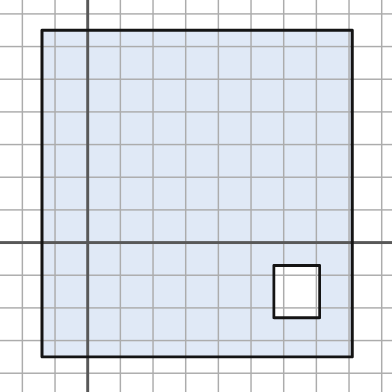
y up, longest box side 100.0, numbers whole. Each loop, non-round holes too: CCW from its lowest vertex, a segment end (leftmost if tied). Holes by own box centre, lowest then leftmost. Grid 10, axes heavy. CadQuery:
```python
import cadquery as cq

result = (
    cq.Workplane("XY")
    .moveTo(-14.0, -35.0)
    .lineTo(81.0, -35.0)
    .lineTo(81.0, 65.0)
    .lineTo(-14.0, 65.0)
    .close()
    .moveTo(57.0, -23.0)
    .lineTo(71.0, -23.0)
    .lineTo(71.0, -7.0)
    .lineTo(57.0, -7.0)
    .close()
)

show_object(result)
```